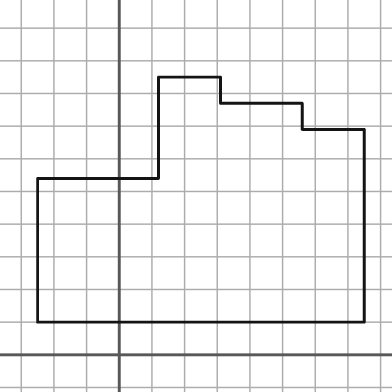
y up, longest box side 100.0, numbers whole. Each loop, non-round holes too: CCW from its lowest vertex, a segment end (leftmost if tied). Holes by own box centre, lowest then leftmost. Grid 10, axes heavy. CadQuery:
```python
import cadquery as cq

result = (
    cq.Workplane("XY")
    .moveTo(-25.0, 10.0)
    .lineTo(75.0, 10.0)
    .lineTo(75.0, 69.0)
    .lineTo(56.0, 69.0)
    .lineTo(56.0, 77.0)
    .lineTo(31.0, 77.0)
    .lineTo(31.0, 85.0)
    .lineTo(12.0, 85.0)
    .lineTo(12.0, 54.0)
    .lineTo(-25.0, 54.0)
    .close()
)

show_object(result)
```